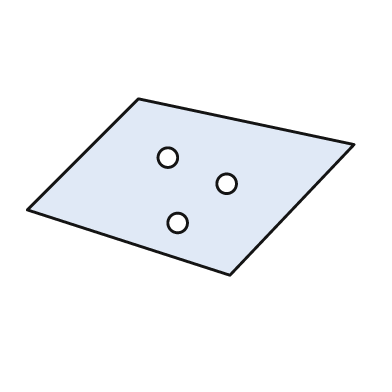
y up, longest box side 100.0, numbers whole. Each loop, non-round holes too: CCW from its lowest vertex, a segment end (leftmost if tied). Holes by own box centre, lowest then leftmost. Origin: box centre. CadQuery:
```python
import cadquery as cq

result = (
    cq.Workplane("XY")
    .moveTo(12.0, -27.0)
    .lineTo(50.0, 13.0)
    .lineTo(-16.0, 27.0)
    .lineTo(-50.0, -7.0)
    .close()
    .moveTo(-4.0, -11.0)
    .circle(3.0)
    .moveTo(11.0, 1.0)
    .circle(3.0)
    .moveTo(-7.0, 9.0)
    .circle(3.0)
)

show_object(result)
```